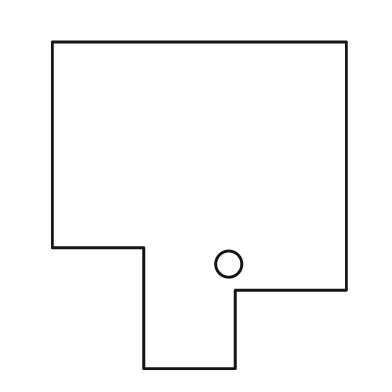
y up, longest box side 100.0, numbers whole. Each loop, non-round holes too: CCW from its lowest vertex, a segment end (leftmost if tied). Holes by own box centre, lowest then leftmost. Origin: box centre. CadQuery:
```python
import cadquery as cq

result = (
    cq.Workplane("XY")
    .moveTo(-17.0, -50.0)
    .lineTo(11.0, -50.0)
    .lineTo(11.0, -26.0)
    .lineTo(45.0, -26.0)
    .lineTo(45.0, 50.0)
    .lineTo(-45.0, 50.0)
    .lineTo(-45.0, -13.0)
    .lineTo(-17.0, -13.0)
    .close()
    .moveTo(9.0, -18.0)
    .circle(4.0)
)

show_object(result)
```